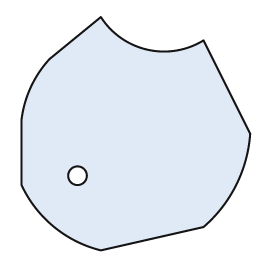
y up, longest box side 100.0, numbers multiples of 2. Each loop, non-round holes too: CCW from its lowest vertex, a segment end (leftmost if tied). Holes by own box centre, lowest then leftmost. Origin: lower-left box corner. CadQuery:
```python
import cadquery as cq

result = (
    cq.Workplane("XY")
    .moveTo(34.0, 0.0)
    .lineTo(78.0, 10.0)
    .threePointArc((92.0, 28.0), (98.0, 50.0))
    .lineTo(78.0, 90.0)
    .threePointArc((54.0, 86.0), (34.0, 100.0))
    .lineTo(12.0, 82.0)
    .threePointArc((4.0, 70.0), (0.0, 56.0))
    .lineTo(0.0, 28.0)
    .threePointArc((14.0, 10.0), (34.0, 0.0))
    .close()
    .moveTo(24.0, 32.0)
    .circle(4.0)
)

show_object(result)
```